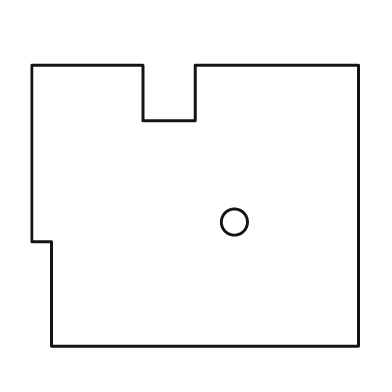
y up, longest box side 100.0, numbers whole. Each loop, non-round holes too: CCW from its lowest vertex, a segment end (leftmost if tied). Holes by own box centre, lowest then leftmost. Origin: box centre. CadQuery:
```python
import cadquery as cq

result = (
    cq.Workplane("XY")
    .moveTo(-44.0, -43.0)
    .lineTo(50.0, -43.0)
    .lineTo(50.0, 43.0)
    .lineTo(0.0, 43.0)
    .lineTo(0.0, 26.0)
    .lineTo(-16.0, 26.0)
    .lineTo(-16.0, 43.0)
    .lineTo(-50.0, 43.0)
    .lineTo(-50.0, -11.0)
    .lineTo(-44.0, -11.0)
    .close()
    .moveTo(12.0, -5.0)
    .circle(4.0)
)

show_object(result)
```